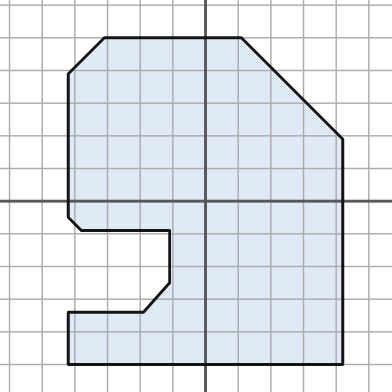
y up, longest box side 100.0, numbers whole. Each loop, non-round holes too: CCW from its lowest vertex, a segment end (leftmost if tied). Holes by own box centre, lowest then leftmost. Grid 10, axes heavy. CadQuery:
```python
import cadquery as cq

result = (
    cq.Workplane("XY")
    .moveTo(-42.0, -50.0)
    .lineTo(42.0, -50.0)
    .lineTo(42.0, 19.0)
    .lineTo(11.0, 50.0)
    .lineTo(-31.0, 50.0)
    .lineTo(-42.0, 39.0)
    .lineTo(-42.0, -5.0)
    .lineTo(-38.0, -9.0)
    .lineTo(-11.0, -9.0)
    .lineTo(-11.0, -25.0)
    .lineTo(-19.0, -34.0)
    .lineTo(-42.0, -34.0)
    .close()
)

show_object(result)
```